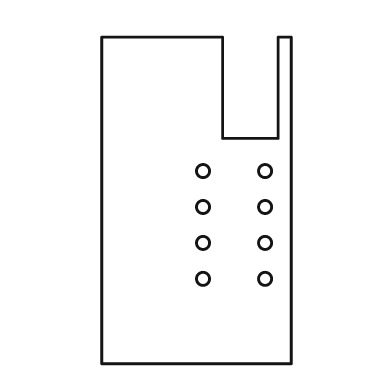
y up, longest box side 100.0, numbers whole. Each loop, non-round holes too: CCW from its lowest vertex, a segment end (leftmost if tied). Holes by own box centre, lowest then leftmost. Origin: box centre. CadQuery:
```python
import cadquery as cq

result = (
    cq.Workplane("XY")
    .moveTo(-29.0, -50.0)
    .lineTo(29.0, -50.0)
    .lineTo(29.0, 50.0)
    .lineTo(25.0, 50.0)
    .lineTo(25.0, 19.0)
    .lineTo(8.0, 19.0)
    .lineTo(8.0, 50.0)
    .lineTo(-29.0, 50.0)
    .close()
    .moveTo(2.0, -24.0)
    .circle(2.0)
    .moveTo(21.0, -24.0)
    .circle(2.0)
    .moveTo(2.0, -13.0)
    .circle(2.0)
    .moveTo(21.0, -13.0)
    .circle(2.0)
    .moveTo(2.0, -2.0)
    .circle(2.0)
    .moveTo(21.0, -2.0)
    .circle(2.0)
    .moveTo(2.0, 9.0)
    .circle(2.0)
    .moveTo(21.0, 9.0)
    .circle(2.0)
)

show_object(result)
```